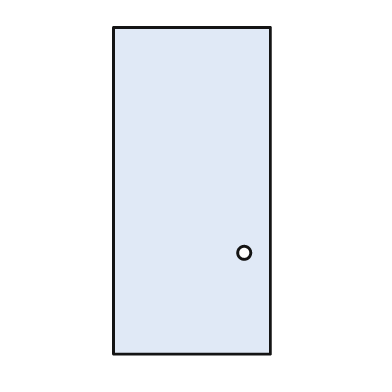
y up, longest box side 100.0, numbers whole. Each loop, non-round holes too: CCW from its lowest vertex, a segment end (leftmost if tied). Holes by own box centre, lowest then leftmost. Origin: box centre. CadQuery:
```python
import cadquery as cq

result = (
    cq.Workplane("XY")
    .moveTo(-24.0, -50.0)
    .lineTo(24.0, -50.0)
    .lineTo(24.0, 50.0)
    .lineTo(-24.0, 50.0)
    .close()
    .moveTo(16.0, -19.0)
    .circle(2.0)
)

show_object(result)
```